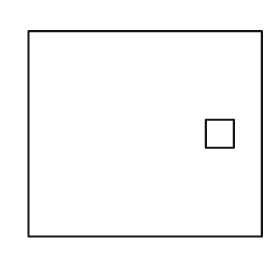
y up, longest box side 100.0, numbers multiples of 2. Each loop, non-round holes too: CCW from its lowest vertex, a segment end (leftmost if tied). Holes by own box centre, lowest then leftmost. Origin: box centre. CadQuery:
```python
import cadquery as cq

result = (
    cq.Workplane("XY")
    .moveTo(-50.0, -44.0)
    .lineTo(50.0, -44.0)
    .lineTo(50.0, 44.0)
    .lineTo(-50.0, 44.0)
    .close()
    .moveTo(26.0, -6.0)
    .lineTo(38.0, -6.0)
    .lineTo(38.0, 6.0)
    .lineTo(26.0, 6.0)
    .close()
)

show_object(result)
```